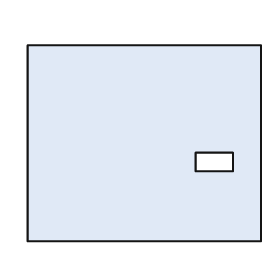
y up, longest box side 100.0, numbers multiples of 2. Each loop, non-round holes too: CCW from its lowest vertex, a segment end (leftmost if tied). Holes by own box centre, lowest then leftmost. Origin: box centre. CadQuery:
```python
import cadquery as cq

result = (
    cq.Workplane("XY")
    .moveTo(-50.0, -42.0)
    .lineTo(50.0, -42.0)
    .lineTo(50.0, 42.0)
    .lineTo(-50.0, 42.0)
    .close()
    .moveTo(22.0, -12.0)
    .lineTo(38.0, -12.0)
    .lineTo(38.0, -4.0)
    .lineTo(22.0, -4.0)
    .close()
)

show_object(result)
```